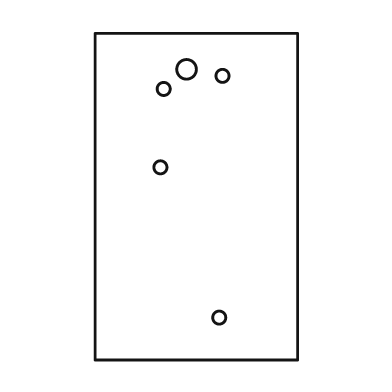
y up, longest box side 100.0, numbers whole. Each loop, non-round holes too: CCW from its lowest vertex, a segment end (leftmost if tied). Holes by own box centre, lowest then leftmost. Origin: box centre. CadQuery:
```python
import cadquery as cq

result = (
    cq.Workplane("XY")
    .moveTo(-31.0, -50.0)
    .lineTo(31.0, -50.0)
    .lineTo(31.0, 50.0)
    .lineTo(-31.0, 50.0)
    .close()
    .moveTo(7.0, -37.0)
    .circle(2.0)
    .moveTo(-11.0, 9.0)
    .circle(2.0)
    .moveTo(-10.0, 33.0)
    .circle(2.0)
    .moveTo(8.0, 37.0)
    .circle(2.0)
    .moveTo(-3.0, 39.0)
    .circle(3.0)
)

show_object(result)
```